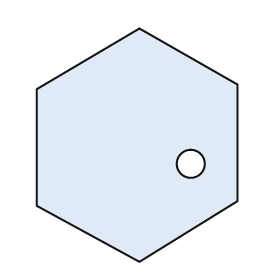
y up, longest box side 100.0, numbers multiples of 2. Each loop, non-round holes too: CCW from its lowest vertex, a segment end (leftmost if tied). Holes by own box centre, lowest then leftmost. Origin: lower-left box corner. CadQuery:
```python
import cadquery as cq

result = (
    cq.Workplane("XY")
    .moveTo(44.0, 0.0)
    .lineTo(86.0, 26.0)
    .lineTo(86.0, 76.0)
    .lineTo(44.0, 100.0)
    .lineTo(0.0, 74.0)
    .lineTo(0.0, 24.0)
    .close()
    .moveTo(66.0, 42.0)
    .circle(6.0)
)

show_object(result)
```